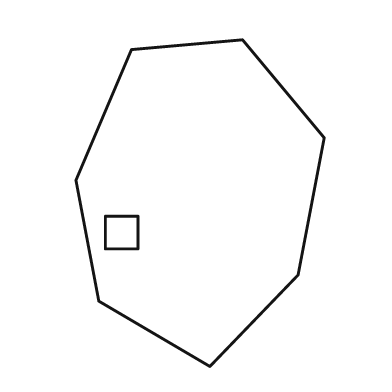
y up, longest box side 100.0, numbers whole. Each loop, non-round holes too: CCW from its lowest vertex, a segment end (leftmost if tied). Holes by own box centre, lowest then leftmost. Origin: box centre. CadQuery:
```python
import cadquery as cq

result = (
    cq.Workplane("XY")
    .moveTo(3.0, -50.0)
    .lineTo(30.0, -22.0)
    .lineTo(38.0, 20.0)
    .lineTo(13.0, 50.0)
    .lineTo(-21.0, 47.0)
    .lineTo(-38.0, 7.0)
    .lineTo(-31.0, -30.0)
    .close()
    .moveTo(-29.0, -14.0)
    .lineTo(-19.0, -14.0)
    .lineTo(-19.0, -4.0)
    .lineTo(-29.0, -4.0)
    .close()
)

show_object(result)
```